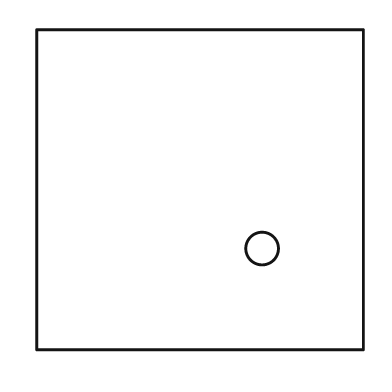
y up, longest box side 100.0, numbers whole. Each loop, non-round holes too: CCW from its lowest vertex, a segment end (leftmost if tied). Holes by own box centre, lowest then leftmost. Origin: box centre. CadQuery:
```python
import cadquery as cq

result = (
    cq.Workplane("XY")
    .moveTo(-50.0, -49.0)
    .lineTo(50.0, -49.0)
    .lineTo(50.0, 49.0)
    .lineTo(-50.0, 49.0)
    .close()
    .moveTo(19.0, -18.0)
    .circle(5.0)
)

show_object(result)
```